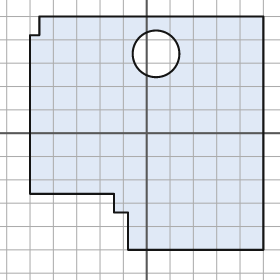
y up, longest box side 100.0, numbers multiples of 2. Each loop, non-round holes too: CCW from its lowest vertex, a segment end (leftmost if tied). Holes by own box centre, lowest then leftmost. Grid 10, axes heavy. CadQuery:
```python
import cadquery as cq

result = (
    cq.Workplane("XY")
    .moveTo(-8.0, -50.0)
    .lineTo(50.0, -50.0)
    .lineTo(50.0, 50.0)
    .lineTo(-46.0, 50.0)
    .lineTo(-46.0, 42.0)
    .lineTo(-50.0, 42.0)
    .lineTo(-50.0, -26.0)
    .lineTo(-14.0, -26.0)
    .lineTo(-14.0, -34.0)
    .lineTo(-8.0, -34.0)
    .close()
    .moveTo(4.0, 34.0)
    .circle(10.0)
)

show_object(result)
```